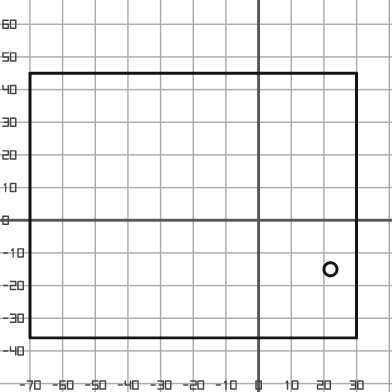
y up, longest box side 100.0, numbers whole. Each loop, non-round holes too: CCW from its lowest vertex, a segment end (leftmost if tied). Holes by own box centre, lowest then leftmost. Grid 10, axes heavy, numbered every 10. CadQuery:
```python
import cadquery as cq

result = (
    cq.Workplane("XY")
    .moveTo(-70.0, -36.0)
    .lineTo(30.0, -36.0)
    .lineTo(30.0, 45.0)
    .lineTo(-70.0, 45.0)
    .close()
    .moveTo(22.0, -15.0)
    .circle(2.0)
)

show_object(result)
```